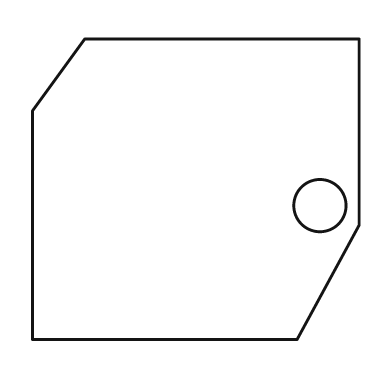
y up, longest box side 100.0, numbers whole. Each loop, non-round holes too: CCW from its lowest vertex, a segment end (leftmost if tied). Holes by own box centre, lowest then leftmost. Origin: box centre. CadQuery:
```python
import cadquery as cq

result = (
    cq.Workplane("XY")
    .moveTo(-50.0, -46.0)
    .lineTo(31.0, -46.0)
    .lineTo(50.0, -11.0)
    .lineTo(50.0, 46.0)
    .lineTo(-34.0, 46.0)
    .lineTo(-50.0, 24.0)
    .close()
    .moveTo(38.0, -5.0)
    .circle(8.0)
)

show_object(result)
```